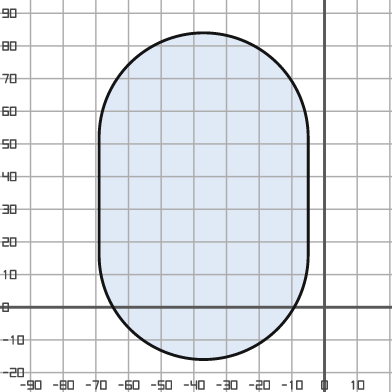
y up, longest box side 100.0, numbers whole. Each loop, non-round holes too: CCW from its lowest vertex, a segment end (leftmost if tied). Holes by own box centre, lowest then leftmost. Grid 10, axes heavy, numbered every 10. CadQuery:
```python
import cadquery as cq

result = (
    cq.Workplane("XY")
    .moveTo(-69.0, 16.0)
    .threePointArc((-37.0, -16.0), (-5.0, 16.0))
    .lineTo(-5.0, 52.0)
    .threePointArc((-37.0, 84.0), (-69.0, 52.0))
    .close()
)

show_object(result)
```